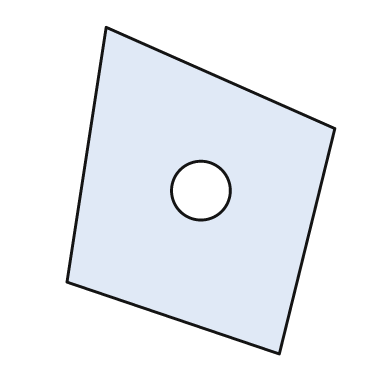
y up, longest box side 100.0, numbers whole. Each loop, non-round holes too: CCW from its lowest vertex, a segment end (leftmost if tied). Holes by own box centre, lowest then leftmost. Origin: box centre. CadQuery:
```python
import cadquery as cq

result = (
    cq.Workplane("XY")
    .moveTo(24.0, -50.0)
    .lineTo(41.0, 19.0)
    .lineTo(-29.0, 50.0)
    .lineTo(-41.0, -28.0)
    .close()
    .moveTo(0.0, 0.0)
    .circle(9.0)
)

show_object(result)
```